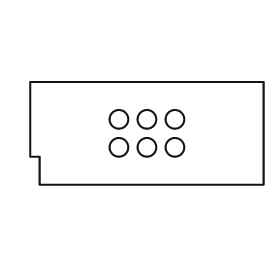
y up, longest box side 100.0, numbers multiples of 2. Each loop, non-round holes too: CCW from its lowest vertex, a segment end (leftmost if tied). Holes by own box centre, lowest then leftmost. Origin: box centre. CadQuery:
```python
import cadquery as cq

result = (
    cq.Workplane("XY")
    .moveTo(-46.0, -22.0)
    .lineTo(50.0, -22.0)
    .lineTo(50.0, 22.0)
    .lineTo(-50.0, 22.0)
    .lineTo(-50.0, -10.0)
    .lineTo(-46.0, -10.0)
    .close()
    .moveTo(-12.0, -6.0)
    .circle(4.0)
    .moveTo(0.0, -6.0)
    .circle(4.0)
    .moveTo(12.0, -6.0)
    .circle(4.0)
    .moveTo(-12.0, 6.0)
    .circle(4.0)
    .moveTo(0.0, 6.0)
    .circle(4.0)
    .moveTo(12.0, 6.0)
    .circle(4.0)
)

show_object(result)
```